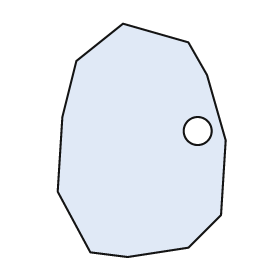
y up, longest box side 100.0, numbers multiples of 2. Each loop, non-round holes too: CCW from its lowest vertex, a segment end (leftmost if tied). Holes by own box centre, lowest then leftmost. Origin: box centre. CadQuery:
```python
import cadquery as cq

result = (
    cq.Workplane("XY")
    .moveTo(-6.0, -50.0)
    .lineTo(20.0, -46.0)
    .lineTo(34.0, -32.0)
    .lineTo(36.0, 0.0)
    .lineTo(28.0, 28.0)
    .lineTo(20.0, 42.0)
    .lineTo(-8.0, 50.0)
    .lineTo(-28.0, 34.0)
    .lineTo(-34.0, 10.0)
    .lineTo(-36.0, -22.0)
    .lineTo(-22.0, -48.0)
    .close()
    .moveTo(24.0, 4.0)
    .circle(6.0)
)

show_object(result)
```